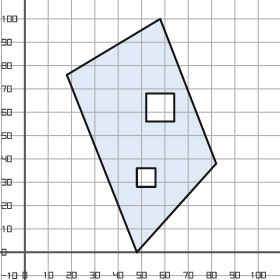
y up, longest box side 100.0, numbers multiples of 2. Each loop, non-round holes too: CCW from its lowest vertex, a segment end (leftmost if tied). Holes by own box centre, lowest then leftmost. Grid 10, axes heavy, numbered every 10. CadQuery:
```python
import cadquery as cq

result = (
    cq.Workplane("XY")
    .moveTo(48.0, 0.0)
    .lineTo(82.0, 38.0)
    .lineTo(58.0, 100.0)
    .lineTo(18.0, 76.0)
    .close()
    .moveTo(48.0, 28.0)
    .lineTo(56.0, 28.0)
    .lineTo(56.0, 36.0)
    .lineTo(48.0, 36.0)
    .close()
    .moveTo(52.0, 56.0)
    .lineTo(64.0, 56.0)
    .lineTo(64.0, 68.0)
    .lineTo(52.0, 68.0)
    .close()
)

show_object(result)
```